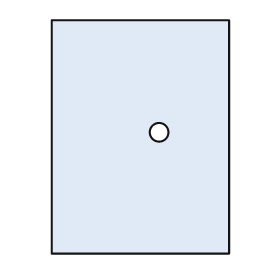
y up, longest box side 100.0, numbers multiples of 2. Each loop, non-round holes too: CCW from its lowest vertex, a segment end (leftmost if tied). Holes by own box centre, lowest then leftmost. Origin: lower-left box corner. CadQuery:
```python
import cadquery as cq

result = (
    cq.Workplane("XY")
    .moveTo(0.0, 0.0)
    .lineTo(76.0, 0.0)
    .lineTo(76.0, 100.0)
    .lineTo(0.0, 100.0)
    .close()
    .moveTo(46.0, 52.0)
    .circle(4.0)
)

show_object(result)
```